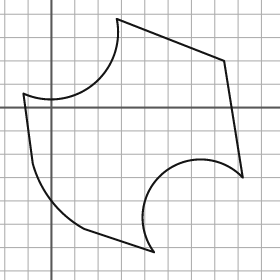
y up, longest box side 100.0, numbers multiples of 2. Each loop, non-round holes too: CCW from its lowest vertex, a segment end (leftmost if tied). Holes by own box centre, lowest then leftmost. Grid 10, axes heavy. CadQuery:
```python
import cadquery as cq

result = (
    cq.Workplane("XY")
    .moveTo(44.0, -62.0)
    .threePointArc((48.0, -28.0), (82.0, -30.0))
    .lineTo(74.0, 20.0)
    .lineTo(28.0, 38.0)
    .threePointArc((18.0, 10.0), (-12.0, 6.0))
    .lineTo(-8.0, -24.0)
    .threePointArc((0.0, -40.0), (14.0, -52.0))
    .close()
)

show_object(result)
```